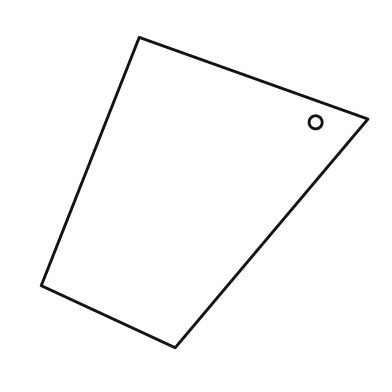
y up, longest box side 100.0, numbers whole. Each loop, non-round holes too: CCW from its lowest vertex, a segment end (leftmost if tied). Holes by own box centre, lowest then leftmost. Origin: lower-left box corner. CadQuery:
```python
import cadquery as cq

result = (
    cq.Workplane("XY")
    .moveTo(41.0, 0.0)
    .lineTo(100.0, 70.0)
    .lineTo(30.0, 95.0)
    .lineTo(0.0, 19.0)
    .close()
    .moveTo(84.0, 69.0)
    .circle(2.0)
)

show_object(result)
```